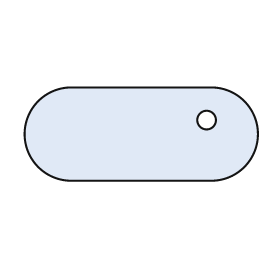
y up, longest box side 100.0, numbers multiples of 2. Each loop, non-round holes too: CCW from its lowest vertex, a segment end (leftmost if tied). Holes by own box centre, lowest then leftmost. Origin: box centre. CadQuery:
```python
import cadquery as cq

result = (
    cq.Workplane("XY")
    .moveTo(-30.0, -20.0)
    .lineTo(30.0, -20.0)
    .threePointArc((50.0, 0.0), (30.0, 20.0))
    .lineTo(-30.0, 20.0)
    .threePointArc((-50.0, 0.0), (-30.0, -20.0))
    .close()
    .moveTo(28.0, 6.0)
    .circle(4.0)
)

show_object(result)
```